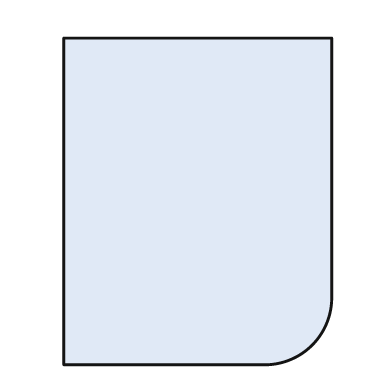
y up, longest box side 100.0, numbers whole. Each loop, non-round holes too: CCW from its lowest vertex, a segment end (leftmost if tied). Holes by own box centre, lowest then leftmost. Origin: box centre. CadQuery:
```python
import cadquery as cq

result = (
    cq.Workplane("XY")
    .moveTo(-41.0, -50.0)
    .lineTo(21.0, -50.0)
    .threePointArc((35.0, -44.0), (41.0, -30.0))
    .lineTo(41.0, 50.0)
    .lineTo(-41.0, 50.0)
    .close()
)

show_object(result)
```